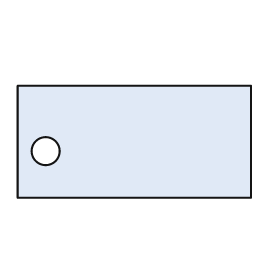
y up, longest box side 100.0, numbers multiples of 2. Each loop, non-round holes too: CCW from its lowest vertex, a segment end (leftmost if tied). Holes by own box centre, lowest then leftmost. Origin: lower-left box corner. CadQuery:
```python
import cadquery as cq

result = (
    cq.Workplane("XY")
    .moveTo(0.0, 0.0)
    .lineTo(100.0, 0.0)
    .lineTo(100.0, 48.0)
    .lineTo(0.0, 48.0)
    .close()
    .moveTo(12.0, 20.0)
    .circle(6.0)
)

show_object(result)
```